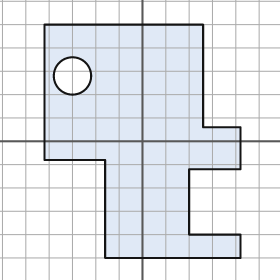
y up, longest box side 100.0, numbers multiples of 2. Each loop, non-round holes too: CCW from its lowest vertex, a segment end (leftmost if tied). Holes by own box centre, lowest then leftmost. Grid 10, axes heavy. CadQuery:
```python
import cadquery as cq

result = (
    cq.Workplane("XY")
    .moveTo(-16.0, -50.0)
    .lineTo(42.0, -50.0)
    .lineTo(42.0, -40.0)
    .lineTo(20.0, -40.0)
    .lineTo(20.0, -12.0)
    .lineTo(42.0, -12.0)
    .lineTo(42.0, 6.0)
    .lineTo(26.0, 6.0)
    .lineTo(26.0, 50.0)
    .lineTo(-42.0, 50.0)
    .lineTo(-42.0, -8.0)
    .lineTo(-16.0, -8.0)
    .close()
    .moveTo(-30.0, 28.0)
    .circle(8.0)
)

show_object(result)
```